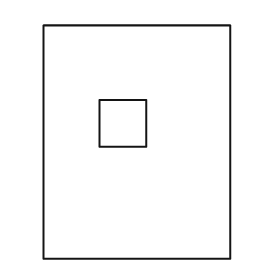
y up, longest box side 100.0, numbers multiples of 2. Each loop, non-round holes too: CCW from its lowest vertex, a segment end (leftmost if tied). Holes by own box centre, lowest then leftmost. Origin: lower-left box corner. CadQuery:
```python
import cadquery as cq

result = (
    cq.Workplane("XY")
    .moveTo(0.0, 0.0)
    .lineTo(80.0, 0.0)
    .lineTo(80.0, 100.0)
    .lineTo(0.0, 100.0)
    .close()
    .moveTo(24.0, 48.0)
    .lineTo(44.0, 48.0)
    .lineTo(44.0, 68.0)
    .lineTo(24.0, 68.0)
    .close()
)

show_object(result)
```